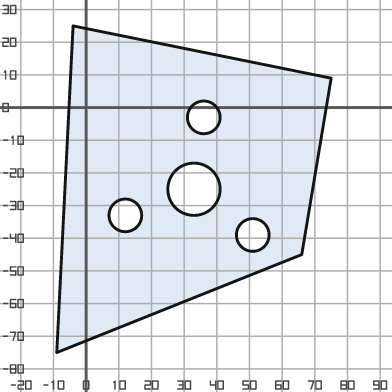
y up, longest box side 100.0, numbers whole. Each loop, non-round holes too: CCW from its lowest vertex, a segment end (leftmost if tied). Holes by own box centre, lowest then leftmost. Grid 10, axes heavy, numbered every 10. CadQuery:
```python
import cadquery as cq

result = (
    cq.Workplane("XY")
    .moveTo(-9.0, -75.0)
    .lineTo(66.0, -45.0)
    .lineTo(75.0, 9.0)
    .lineTo(-4.0, 25.0)
    .close()
    .moveTo(51.0, -39.0)
    .circle(5.0)
    .moveTo(12.0, -33.0)
    .circle(5.0)
    .moveTo(33.0, -25.0)
    .circle(8.0)
    .moveTo(36.0, -3.0)
    .circle(5.0)
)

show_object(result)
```